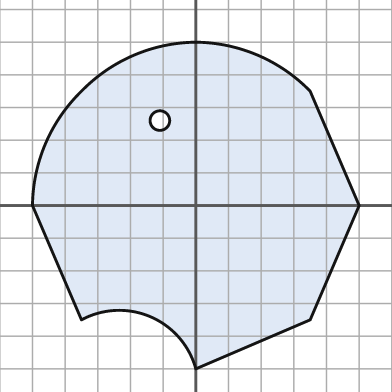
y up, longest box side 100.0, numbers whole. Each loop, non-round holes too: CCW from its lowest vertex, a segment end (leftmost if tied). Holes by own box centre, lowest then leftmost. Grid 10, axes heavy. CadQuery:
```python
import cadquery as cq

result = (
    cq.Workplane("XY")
    .moveTo(0.0, -50.0)
    .lineTo(35.0, -35.0)
    .lineTo(50.0, 0.0)
    .lineTo(35.0, 35.0)
    .threePointArc((19.0, 46.0), (0.0, 50.0))
    .threePointArc((-19.0, 46.0), (-35.0, 35.0))
    .threePointArc((-46.0, 19.0), (-50.0, 0.0))
    .lineTo(-35.0, -35.0)
    .threePointArc((-14.0, -34.0), (0.0, -50.0))
    .close()
    .moveTo(-11.0, 26.0)
    .circle(3.0)
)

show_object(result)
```